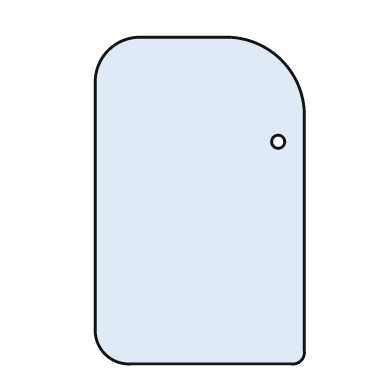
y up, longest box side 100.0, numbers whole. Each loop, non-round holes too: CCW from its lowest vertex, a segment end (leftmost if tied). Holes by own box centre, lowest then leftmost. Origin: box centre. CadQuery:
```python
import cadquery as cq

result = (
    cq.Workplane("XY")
    .moveTo(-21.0, -50.0)
    .lineTo(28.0, -50.0)
    .threePointArc((31.0, -49.0), (32.0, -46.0))
    .lineTo(32.0, 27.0)
    .threePointArc((25.0, 43.0), (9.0, 50.0))
    .lineTo(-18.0, 50.0)
    .threePointArc((-28.0, 46.0), (-32.0, 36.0))
    .lineTo(-32.0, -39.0)
    .threePointArc((-29.0, -47.0), (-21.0, -50.0))
    .close()
    .moveTo(24.0, 18.0)
    .circle(2.0)
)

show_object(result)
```